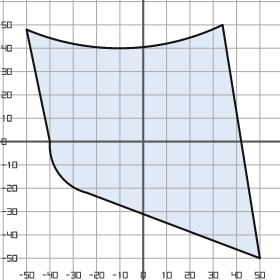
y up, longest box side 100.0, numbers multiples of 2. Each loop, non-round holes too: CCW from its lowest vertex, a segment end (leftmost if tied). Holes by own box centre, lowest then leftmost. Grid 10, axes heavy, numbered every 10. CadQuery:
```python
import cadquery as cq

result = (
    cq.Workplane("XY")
    .moveTo(50.0, -50.0)
    .lineTo(34.0, 50.0)
    .threePointArc((-8.0, 40.0), (-50.0, 48.0))
    .lineTo(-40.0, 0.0)
    .threePointArc((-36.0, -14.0), (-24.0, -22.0))
    .close()
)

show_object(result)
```